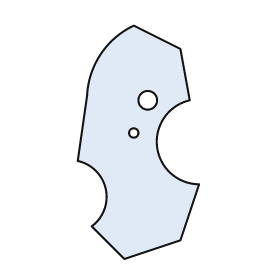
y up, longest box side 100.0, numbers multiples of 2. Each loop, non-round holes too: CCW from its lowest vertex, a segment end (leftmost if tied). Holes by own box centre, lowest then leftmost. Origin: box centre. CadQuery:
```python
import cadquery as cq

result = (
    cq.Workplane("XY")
    .moveTo(-6.0, -50.0)
    .lineTo(18.0, -42.0)
    .lineTo(26.0, -18.0)
    .threePointArc((8.0, -2.0), (22.0, 18.0))
    .lineTo(18.0, 40.0)
    .lineTo(-2.0, 50.0)
    .threePointArc((-16.0, 38.0), (-22.0, 20.0))
    .lineTo(-26.0, -8.0)
    .threePointArc((-14.0, -20.0), (-20.0, -36.0))
    .close()
    .moveTo(-2.0, 4.0)
    .circle(2.0)
    .moveTo(4.0, 18.0)
    .circle(4.0)
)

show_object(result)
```